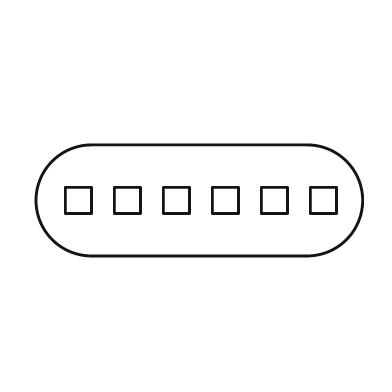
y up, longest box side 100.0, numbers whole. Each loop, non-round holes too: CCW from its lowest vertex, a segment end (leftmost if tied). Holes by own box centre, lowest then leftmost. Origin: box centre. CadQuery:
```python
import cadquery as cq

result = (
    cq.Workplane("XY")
    .moveTo(-33.0, -17.0)
    .lineTo(33.0, -17.0)
    .threePointArc((50.0, 0.0), (33.0, 17.0))
    .lineTo(-33.0, 17.0)
    .threePointArc((-50.0, 0.0), (-33.0, -17.0))
    .close()
    .moveTo(-41.0, -4.0)
    .lineTo(-33.0, -4.0)
    .lineTo(-33.0, 4.0)
    .lineTo(-41.0, 4.0)
    .close()
    .moveTo(-26.0, -4.0)
    .lineTo(-18.0, -4.0)
    .lineTo(-18.0, 4.0)
    .lineTo(-26.0, 4.0)
    .close()
    .moveTo(-11.0, -4.0)
    .lineTo(-3.0, -4.0)
    .lineTo(-3.0, 4.0)
    .lineTo(-11.0, 4.0)
    .close()
    .moveTo(4.0, -4.0)
    .lineTo(12.0, -4.0)
    .lineTo(12.0, 4.0)
    .lineTo(4.0, 4.0)
    .close()
    .moveTo(19.0, -4.0)
    .lineTo(27.0, -4.0)
    .lineTo(27.0, 4.0)
    .lineTo(19.0, 4.0)
    .close()
    .moveTo(34.0, -4.0)
    .lineTo(42.0, -4.0)
    .lineTo(42.0, 4.0)
    .lineTo(34.0, 4.0)
    .close()
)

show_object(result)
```